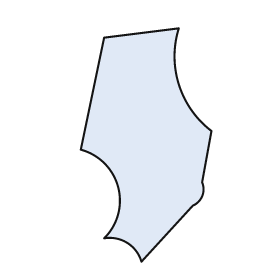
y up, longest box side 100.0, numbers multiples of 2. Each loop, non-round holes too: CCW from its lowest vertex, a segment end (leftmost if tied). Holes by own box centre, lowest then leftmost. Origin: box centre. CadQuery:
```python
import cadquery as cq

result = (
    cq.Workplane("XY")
    .moveTo(-2.0, -50.0)
    .lineTo(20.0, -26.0)
    .threePointArc((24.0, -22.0), (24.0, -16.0))
    .lineTo(28.0, 6.0)
    .threePointArc((14.0, 26.0), (14.0, 50.0))
    .lineTo(-18.0, 46.0)
    .lineTo(-28.0, -2.0)
    .threePointArc((-12.0, -18.0), (-18.0, -40.0))
    .threePointArc((-8.0, -42.0), (-2.0, -50.0))
    .close()
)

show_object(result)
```